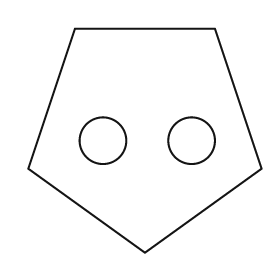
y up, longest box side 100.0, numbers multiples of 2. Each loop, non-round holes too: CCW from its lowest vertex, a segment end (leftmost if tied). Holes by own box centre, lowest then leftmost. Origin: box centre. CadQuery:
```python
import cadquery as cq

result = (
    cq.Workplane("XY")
    .moveTo(0.0, -48.0)
    .lineTo(50.0, -12.0)
    .lineTo(30.0, 48.0)
    .lineTo(-30.0, 48.0)
    .lineTo(-50.0, -12.0)
    .close()
    .moveTo(-18.0, 0.0)
    .circle(10.0)
    .moveTo(20.0, 0.0)
    .circle(10.0)
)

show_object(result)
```